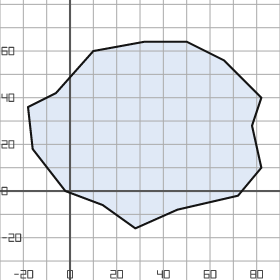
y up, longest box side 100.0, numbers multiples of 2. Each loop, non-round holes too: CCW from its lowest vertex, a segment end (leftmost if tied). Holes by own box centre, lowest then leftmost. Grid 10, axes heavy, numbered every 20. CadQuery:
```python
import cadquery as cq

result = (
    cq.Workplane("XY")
    .moveTo(28.0, -16.0)
    .lineTo(46.0, -8.0)
    .lineTo(72.0, -2.0)
    .lineTo(82.0, 10.0)
    .lineTo(78.0, 28.0)
    .lineTo(82.0, 40.0)
    .lineTo(66.0, 56.0)
    .lineTo(50.0, 64.0)
    .lineTo(32.0, 64.0)
    .lineTo(10.0, 60.0)
    .lineTo(-6.0, 42.0)
    .lineTo(-18.0, 36.0)
    .lineTo(-16.0, 18.0)
    .lineTo(-2.0, 0.0)
    .lineTo(14.0, -6.0)
    .close()
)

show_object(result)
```